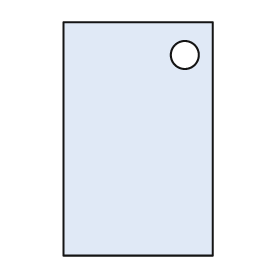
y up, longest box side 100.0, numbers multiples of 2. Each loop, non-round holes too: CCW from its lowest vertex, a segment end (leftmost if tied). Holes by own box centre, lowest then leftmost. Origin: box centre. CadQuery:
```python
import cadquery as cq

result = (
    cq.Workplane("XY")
    .moveTo(-32.0, -50.0)
    .lineTo(32.0, -50.0)
    .lineTo(32.0, 50.0)
    .lineTo(-32.0, 50.0)
    .close()
    .moveTo(20.0, 36.0)
    .circle(6.0)
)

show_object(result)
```